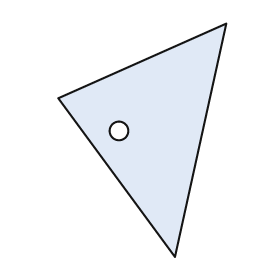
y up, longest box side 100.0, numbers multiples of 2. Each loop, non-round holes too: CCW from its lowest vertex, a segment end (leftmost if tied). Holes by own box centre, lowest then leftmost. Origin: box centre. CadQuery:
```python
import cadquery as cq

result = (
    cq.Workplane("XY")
    .moveTo(14.0, -50.0)
    .lineTo(36.0, 50.0)
    .lineTo(-36.0, 18.0)
    .close()
    .moveTo(-10.0, 4.0)
    .circle(4.0)
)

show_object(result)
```